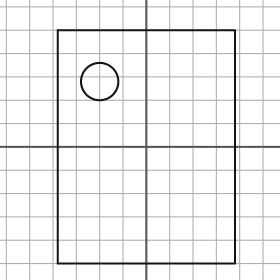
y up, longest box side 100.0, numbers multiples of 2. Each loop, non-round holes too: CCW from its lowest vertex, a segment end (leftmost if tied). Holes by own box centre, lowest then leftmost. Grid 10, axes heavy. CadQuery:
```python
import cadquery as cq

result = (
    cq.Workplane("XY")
    .moveTo(-38.0, -50.0)
    .lineTo(38.0, -50.0)
    .lineTo(38.0, 50.0)
    .lineTo(-38.0, 50.0)
    .close()
    .moveTo(-20.0, 28.0)
    .circle(8.0)
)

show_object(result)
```